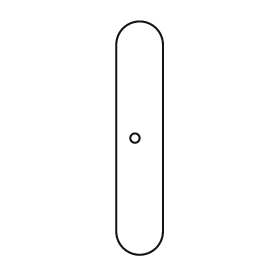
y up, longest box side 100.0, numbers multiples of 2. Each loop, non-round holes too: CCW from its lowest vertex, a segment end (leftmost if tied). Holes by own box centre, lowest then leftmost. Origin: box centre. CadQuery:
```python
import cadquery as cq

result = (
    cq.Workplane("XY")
    .moveTo(-10.0, -40.0)
    .threePointArc((0.0, -50.0), (10.0, -40.0))
    .lineTo(10.0, 40.0)
    .threePointArc((0.0, 50.0), (-10.0, 40.0))
    .close()
    .moveTo(-2.0, 0.0)
    .circle(2.0)
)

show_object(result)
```